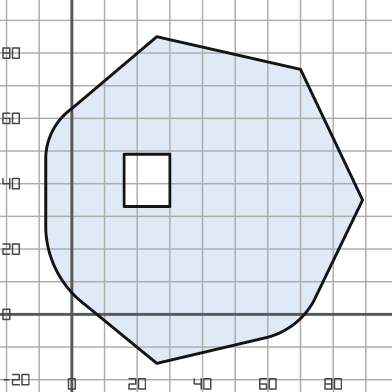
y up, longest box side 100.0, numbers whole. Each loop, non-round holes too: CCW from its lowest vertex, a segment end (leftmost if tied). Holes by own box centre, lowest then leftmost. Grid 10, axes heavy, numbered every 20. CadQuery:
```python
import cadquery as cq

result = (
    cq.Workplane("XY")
    .moveTo(26.0, -15.0)
    .lineTo(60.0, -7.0)
    .threePointArc((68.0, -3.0), (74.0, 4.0))
    .lineTo(89.0, 35.0)
    .lineTo(70.0, 75.0)
    .lineTo(26.0, 85.0)
    .lineTo(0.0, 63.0)
    .threePointArc((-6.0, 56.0), (-8.0, 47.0))
    .lineTo(-8.0, 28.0)
    .threePointArc((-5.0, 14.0), (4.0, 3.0))
    .close()
    .moveTo(16.0, 33.0)
    .lineTo(30.0, 33.0)
    .lineTo(30.0, 49.0)
    .lineTo(16.0, 49.0)
    .close()
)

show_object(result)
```